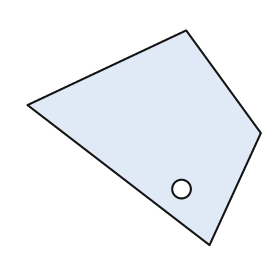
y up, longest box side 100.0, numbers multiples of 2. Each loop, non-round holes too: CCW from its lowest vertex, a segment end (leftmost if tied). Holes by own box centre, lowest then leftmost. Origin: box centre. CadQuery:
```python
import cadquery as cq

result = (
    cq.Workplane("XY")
    .moveTo(28.0, -46.0)
    .lineTo(50.0, 2.0)
    .lineTo(18.0, 46.0)
    .lineTo(-50.0, 14.0)
    .close()
    .moveTo(16.0, -22.0)
    .circle(4.0)
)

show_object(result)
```